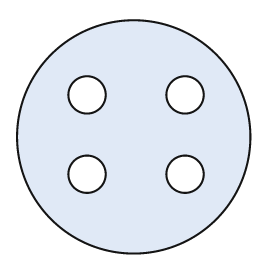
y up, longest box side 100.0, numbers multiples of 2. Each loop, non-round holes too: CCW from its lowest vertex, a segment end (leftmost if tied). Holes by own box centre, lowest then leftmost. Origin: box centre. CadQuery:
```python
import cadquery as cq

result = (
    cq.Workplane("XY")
    .moveTo(0.0, 0.0)
    .circle(50.0)
    .moveTo(-20.0, -16.0)
    .circle(8.0)
    .moveTo(22.0, -16.0)
    .circle(8.0)
    .moveTo(-20.0, 18.0)
    .circle(8.0)
    .moveTo(22.0, 18.0)
    .circle(8.0)
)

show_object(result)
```